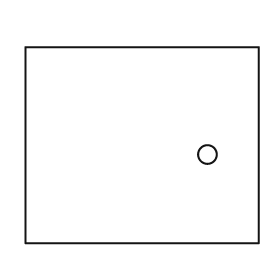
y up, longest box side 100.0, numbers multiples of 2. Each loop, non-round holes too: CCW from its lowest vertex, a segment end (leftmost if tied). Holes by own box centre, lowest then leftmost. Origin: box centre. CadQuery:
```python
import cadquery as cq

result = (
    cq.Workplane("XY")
    .moveTo(-50.0, -42.0)
    .lineTo(50.0, -42.0)
    .lineTo(50.0, 42.0)
    .lineTo(-50.0, 42.0)
    .close()
    .moveTo(28.0, -4.0)
    .circle(4.0)
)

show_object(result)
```